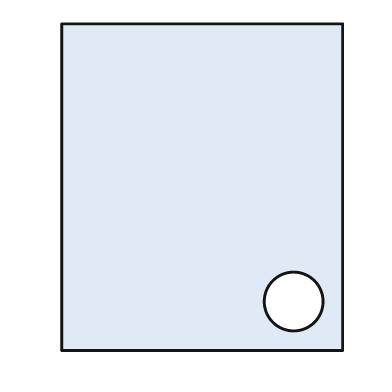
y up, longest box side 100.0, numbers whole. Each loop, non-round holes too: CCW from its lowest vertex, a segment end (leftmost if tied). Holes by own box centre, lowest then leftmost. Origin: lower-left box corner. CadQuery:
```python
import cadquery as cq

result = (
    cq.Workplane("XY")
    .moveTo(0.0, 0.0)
    .lineTo(86.0, 0.0)
    .lineTo(86.0, 100.0)
    .lineTo(0.0, 100.0)
    .close()
    .moveTo(71.0, 15.0)
    .circle(9.0)
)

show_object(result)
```